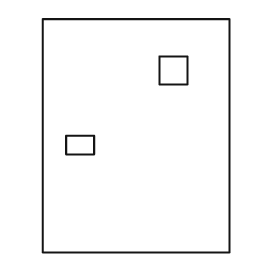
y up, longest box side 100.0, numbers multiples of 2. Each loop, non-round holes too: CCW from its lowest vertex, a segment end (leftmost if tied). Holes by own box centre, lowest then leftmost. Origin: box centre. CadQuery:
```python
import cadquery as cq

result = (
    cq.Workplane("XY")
    .moveTo(-40.0, -50.0)
    .lineTo(40.0, -50.0)
    .lineTo(40.0, 50.0)
    .lineTo(-40.0, 50.0)
    .close()
    .moveTo(-30.0, -8.0)
    .lineTo(-18.0, -8.0)
    .lineTo(-18.0, 0.0)
    .lineTo(-30.0, 0.0)
    .close()
    .moveTo(10.0, 22.0)
    .lineTo(22.0, 22.0)
    .lineTo(22.0, 34.0)
    .lineTo(10.0, 34.0)
    .close()
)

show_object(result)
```